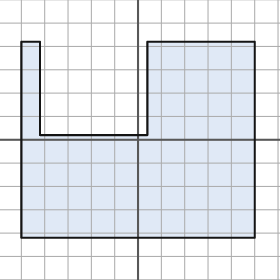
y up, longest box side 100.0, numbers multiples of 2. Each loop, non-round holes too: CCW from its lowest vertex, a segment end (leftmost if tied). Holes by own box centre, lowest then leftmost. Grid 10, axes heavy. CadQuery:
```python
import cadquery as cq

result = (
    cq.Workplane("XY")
    .moveTo(-50.0, -42.0)
    .lineTo(50.0, -42.0)
    .lineTo(50.0, 42.0)
    .lineTo(4.0, 42.0)
    .lineTo(4.0, 2.0)
    .lineTo(-42.0, 2.0)
    .lineTo(-42.0, 42.0)
    .lineTo(-50.0, 42.0)
    .close()
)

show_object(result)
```